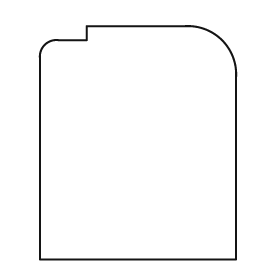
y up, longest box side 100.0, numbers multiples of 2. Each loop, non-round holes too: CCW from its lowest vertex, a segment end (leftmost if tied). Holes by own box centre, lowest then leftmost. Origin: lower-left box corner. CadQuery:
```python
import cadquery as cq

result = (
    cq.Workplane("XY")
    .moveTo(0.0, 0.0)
    .lineTo(84.0, 0.0)
    .lineTo(84.0, 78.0)
    .threePointArc((78.0, 94.0), (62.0, 100.0))
    .lineTo(20.0, 100.0)
    .lineTo(20.0, 94.0)
    .lineTo(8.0, 94.0)
    .threePointArc((2.0, 92.0), (0.0, 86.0))
    .close()
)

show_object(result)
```